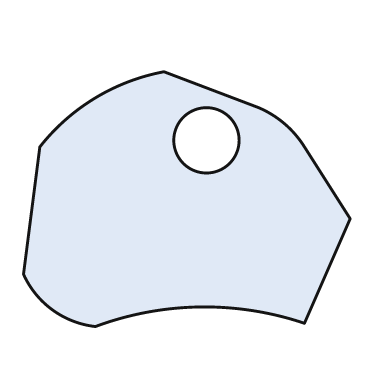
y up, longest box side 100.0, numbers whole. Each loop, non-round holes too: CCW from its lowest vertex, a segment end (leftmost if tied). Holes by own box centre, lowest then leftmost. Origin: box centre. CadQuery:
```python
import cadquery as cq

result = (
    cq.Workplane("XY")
    .moveTo(-28.0, -39.0)
    .threePointArc((4.0, -33.0), (36.0, -38.0))
    .lineTo(50.0, -6.0)
    .lineTo(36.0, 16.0)
    .threePointArc((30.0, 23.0), (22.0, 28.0))
    .lineTo(-7.0, 39.0)
    .threePointArc((-28.0, 31.0), (-45.0, 16.0))
    .lineTo(-50.0, -23.0)
    .threePointArc((-41.0, -34.0), (-28.0, -39.0))
    .close()
    .moveTo(6.0, 18.0)
    .circle(10.0)
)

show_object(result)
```